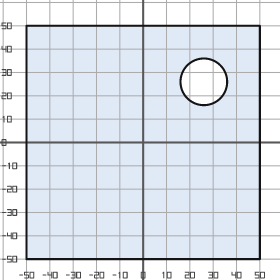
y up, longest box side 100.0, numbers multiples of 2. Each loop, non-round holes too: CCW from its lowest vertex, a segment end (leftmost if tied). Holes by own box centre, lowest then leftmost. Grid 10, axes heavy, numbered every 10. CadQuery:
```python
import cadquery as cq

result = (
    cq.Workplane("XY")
    .moveTo(-50.0, -50.0)
    .lineTo(50.0, -50.0)
    .lineTo(50.0, 50.0)
    .lineTo(-50.0, 50.0)
    .close()
    .moveTo(26.0, 26.0)
    .circle(10.0)
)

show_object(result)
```